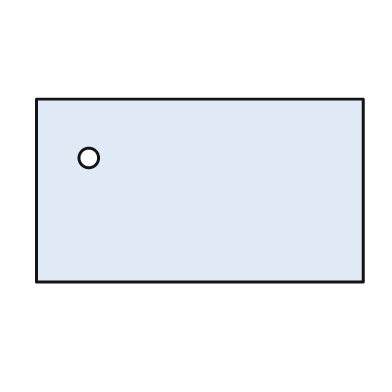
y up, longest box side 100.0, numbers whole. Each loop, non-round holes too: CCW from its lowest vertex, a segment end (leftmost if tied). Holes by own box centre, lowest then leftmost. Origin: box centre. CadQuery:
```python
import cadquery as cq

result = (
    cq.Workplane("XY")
    .moveTo(-50.0, -28.0)
    .lineTo(50.0, -28.0)
    .lineTo(50.0, 28.0)
    .lineTo(-50.0, 28.0)
    .close()
    .moveTo(-34.0, 10.0)
    .circle(3.0)
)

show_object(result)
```